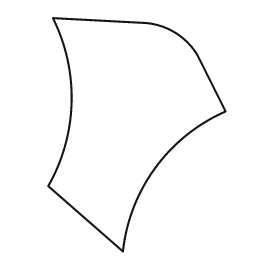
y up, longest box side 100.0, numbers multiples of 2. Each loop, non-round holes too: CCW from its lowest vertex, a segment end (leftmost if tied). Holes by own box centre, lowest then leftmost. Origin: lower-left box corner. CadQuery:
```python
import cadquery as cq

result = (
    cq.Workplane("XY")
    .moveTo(32.0, 0.0)
    .threePointArc((46.0, 36.0), (76.0, 60.0))
    .lineTo(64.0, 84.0)
    .threePointArc((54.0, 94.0), (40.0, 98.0))
    .lineTo(2.0, 100.0)
    .threePointArc((10.0, 64.0), (0.0, 28.0))
    .close()
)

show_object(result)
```